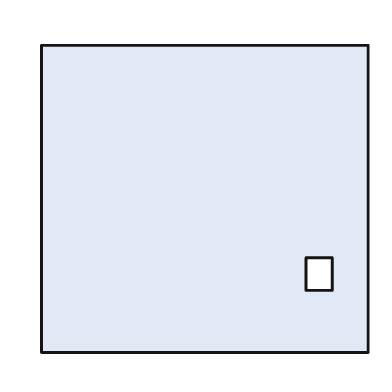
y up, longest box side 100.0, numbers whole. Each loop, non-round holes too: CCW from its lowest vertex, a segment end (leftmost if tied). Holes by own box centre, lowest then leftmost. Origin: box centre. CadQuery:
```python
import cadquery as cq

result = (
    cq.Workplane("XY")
    .moveTo(-50.0, -47.0)
    .lineTo(50.0, -47.0)
    .lineTo(50.0, 47.0)
    .lineTo(-50.0, 47.0)
    .close()
    .moveTo(31.0, -28.0)
    .lineTo(39.0, -28.0)
    .lineTo(39.0, -18.0)
    .lineTo(31.0, -18.0)
    .close()
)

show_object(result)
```